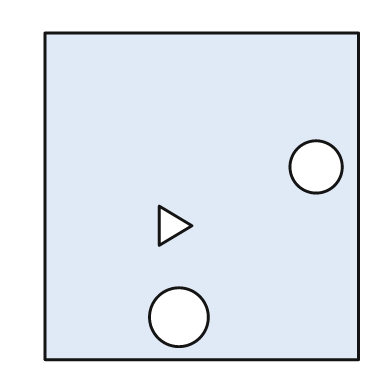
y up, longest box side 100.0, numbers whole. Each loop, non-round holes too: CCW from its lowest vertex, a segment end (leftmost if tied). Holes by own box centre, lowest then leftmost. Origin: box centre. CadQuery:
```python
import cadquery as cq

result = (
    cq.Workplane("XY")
    .moveTo(-48.0, -50.0)
    .lineTo(48.0, -50.0)
    .lineTo(48.0, 50.0)
    .lineTo(-48.0, 50.0)
    .close()
    .moveTo(-7.0, -37.0)
    .circle(9.0)
    .moveTo(-13.0, -15.0)
    .lineTo(-3.0, -9.0)
    .lineTo(-13.0, -3.0)
    .close()
    .moveTo(35.0, 9.0)
    .circle(8.0)
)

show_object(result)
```